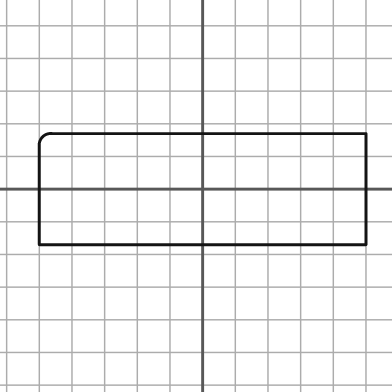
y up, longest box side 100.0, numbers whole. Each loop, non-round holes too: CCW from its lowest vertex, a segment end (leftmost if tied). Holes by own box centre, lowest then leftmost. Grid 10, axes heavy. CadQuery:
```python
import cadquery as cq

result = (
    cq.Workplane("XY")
    .moveTo(-50.0, -17.0)
    .lineTo(50.0, -17.0)
    .lineTo(50.0, 17.0)
    .lineTo(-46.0, 17.0)
    .threePointArc((-49.0, 16.0), (-50.0, 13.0))
    .close()
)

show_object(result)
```